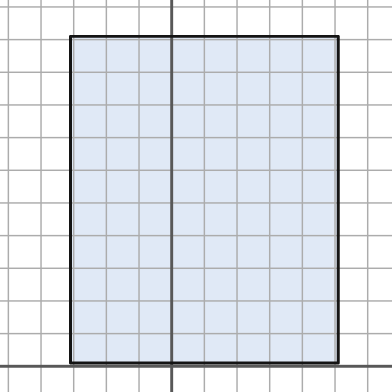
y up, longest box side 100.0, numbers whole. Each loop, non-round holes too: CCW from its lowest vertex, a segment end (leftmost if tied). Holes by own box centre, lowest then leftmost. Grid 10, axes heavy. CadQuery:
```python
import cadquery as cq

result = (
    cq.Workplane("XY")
    .moveTo(-31.0, 1.0)
    .lineTo(51.0, 1.0)
    .lineTo(51.0, 101.0)
    .lineTo(-31.0, 101.0)
    .close()
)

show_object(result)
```